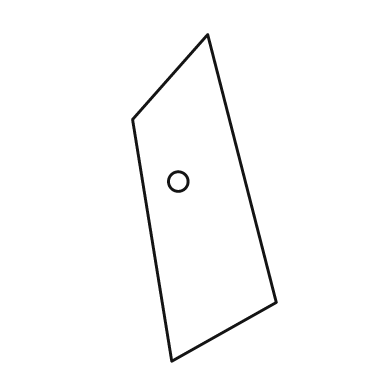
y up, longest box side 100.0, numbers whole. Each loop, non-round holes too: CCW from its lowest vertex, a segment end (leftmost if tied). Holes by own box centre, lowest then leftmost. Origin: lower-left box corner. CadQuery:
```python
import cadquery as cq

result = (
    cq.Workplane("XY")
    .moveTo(12.0, 0.0)
    .lineTo(44.0, 18.0)
    .lineTo(23.0, 100.0)
    .lineTo(0.0, 74.0)
    .close()
    .moveTo(14.0, 55.0)
    .circle(3.0)
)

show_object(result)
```